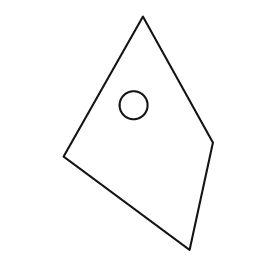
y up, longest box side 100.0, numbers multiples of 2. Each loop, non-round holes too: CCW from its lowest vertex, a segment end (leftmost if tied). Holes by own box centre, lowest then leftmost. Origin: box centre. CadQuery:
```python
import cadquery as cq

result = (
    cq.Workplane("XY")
    .moveTo(22.0, -50.0)
    .lineTo(32.0, -4.0)
    .lineTo(2.0, 50.0)
    .lineTo(-32.0, -10.0)
    .close()
    .moveTo(-2.0, 12.0)
    .circle(6.0)
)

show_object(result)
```